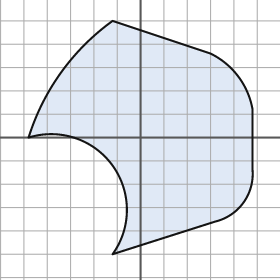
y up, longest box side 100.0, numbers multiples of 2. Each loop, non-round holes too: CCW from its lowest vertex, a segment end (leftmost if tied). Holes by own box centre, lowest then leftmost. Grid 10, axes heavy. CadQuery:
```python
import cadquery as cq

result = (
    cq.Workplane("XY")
    .moveTo(-12.0, -50.0)
    .lineTo(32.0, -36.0)
    .threePointArc((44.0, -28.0), (48.0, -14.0))
    .lineTo(48.0, 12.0)
    .threePointArc((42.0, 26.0), (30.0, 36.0))
    .lineTo(-12.0, 50.0)
    .threePointArc((-34.0, 28.0), (-48.0, 0.0))
    .threePointArc((-12.0, -12.0), (-12.0, -50.0))
    .close()
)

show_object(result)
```